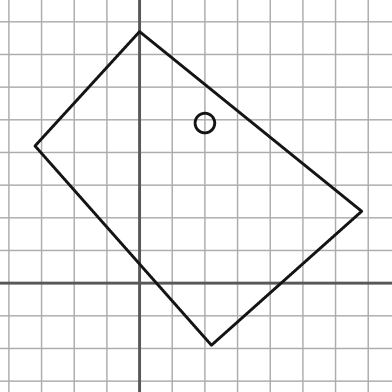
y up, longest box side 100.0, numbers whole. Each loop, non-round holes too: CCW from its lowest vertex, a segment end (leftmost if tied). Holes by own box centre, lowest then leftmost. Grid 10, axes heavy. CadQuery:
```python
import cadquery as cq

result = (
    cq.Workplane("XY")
    .moveTo(22.0, -19.0)
    .lineTo(68.0, 22.0)
    .lineTo(0.0, 77.0)
    .lineTo(-32.0, 42.0)
    .close()
    .moveTo(20.0, 49.0)
    .circle(3.0)
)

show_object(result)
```